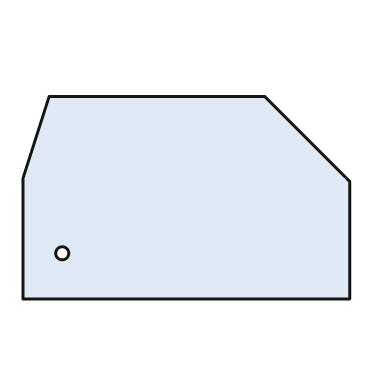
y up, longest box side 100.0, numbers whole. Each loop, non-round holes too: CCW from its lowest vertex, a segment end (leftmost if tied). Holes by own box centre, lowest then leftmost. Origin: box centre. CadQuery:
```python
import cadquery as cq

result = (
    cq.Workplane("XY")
    .moveTo(-50.0, -31.0)
    .lineTo(50.0, -31.0)
    .lineTo(50.0, 5.0)
    .lineTo(24.0, 31.0)
    .lineTo(-42.0, 31.0)
    .lineTo(-50.0, 6.0)
    .close()
    .moveTo(-38.0, -17.0)
    .circle(2.0)
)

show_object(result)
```